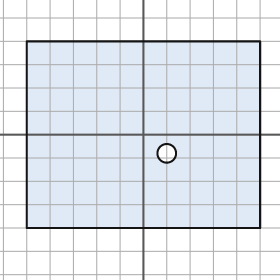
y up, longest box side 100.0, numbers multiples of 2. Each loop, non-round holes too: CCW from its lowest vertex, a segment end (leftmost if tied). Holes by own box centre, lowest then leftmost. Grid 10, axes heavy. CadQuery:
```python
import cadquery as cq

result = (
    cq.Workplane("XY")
    .moveTo(-50.0, -40.0)
    .lineTo(50.0, -40.0)
    .lineTo(50.0, 40.0)
    .lineTo(-50.0, 40.0)
    .close()
    .moveTo(10.0, -8.0)
    .circle(4.0)
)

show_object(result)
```